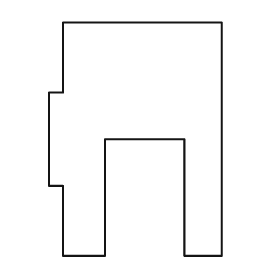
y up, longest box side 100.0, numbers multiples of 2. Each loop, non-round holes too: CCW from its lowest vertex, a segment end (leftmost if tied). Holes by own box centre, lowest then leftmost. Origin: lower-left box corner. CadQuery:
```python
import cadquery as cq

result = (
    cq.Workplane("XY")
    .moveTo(6.0, 0.0)
    .lineTo(24.0, 0.0)
    .lineTo(24.0, 50.0)
    .lineTo(58.0, 50.0)
    .lineTo(58.0, 0.0)
    .lineTo(74.0, 0.0)
    .lineTo(74.0, 100.0)
    .lineTo(6.0, 100.0)
    .lineTo(6.0, 70.0)
    .lineTo(0.0, 70.0)
    .lineTo(0.0, 30.0)
    .lineTo(6.0, 30.0)
    .close()
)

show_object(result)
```